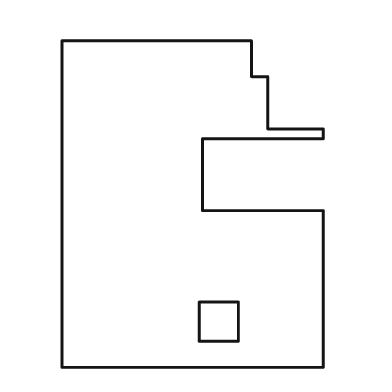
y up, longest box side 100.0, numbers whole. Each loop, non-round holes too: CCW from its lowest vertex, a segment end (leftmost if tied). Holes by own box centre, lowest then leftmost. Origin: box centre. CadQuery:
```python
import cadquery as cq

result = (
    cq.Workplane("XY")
    .moveTo(-40.0, -50.0)
    .lineTo(40.0, -50.0)
    .lineTo(40.0, -2.0)
    .lineTo(3.0, -2.0)
    .lineTo(3.0, 20.0)
    .lineTo(40.0, 20.0)
    .lineTo(40.0, 23.0)
    .lineTo(23.0, 23.0)
    .lineTo(23.0, 39.0)
    .lineTo(18.0, 39.0)
    .lineTo(18.0, 50.0)
    .lineTo(-40.0, 50.0)
    .close()
    .moveTo(2.0, -42.0)
    .lineTo(14.0, -42.0)
    .lineTo(14.0, -30.0)
    .lineTo(2.0, -30.0)
    .close()
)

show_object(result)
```